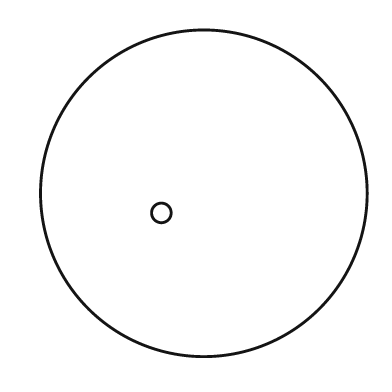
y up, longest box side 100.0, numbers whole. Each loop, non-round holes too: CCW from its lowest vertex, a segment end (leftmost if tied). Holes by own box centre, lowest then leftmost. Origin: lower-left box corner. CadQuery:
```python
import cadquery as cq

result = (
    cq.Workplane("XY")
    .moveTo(50.0, 50.0)
    .circle(50.0)
    .moveTo(37.0, 44.0)
    .circle(3.0)
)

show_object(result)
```